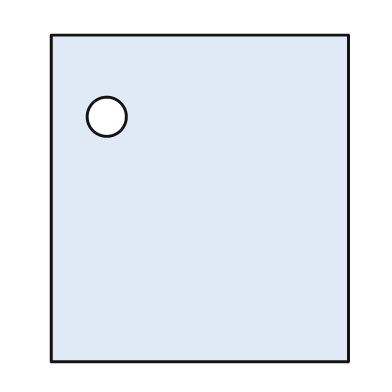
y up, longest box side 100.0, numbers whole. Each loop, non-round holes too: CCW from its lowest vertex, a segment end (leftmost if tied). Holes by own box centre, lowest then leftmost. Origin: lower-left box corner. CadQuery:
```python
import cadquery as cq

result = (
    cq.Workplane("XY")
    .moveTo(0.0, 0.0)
    .lineTo(91.0, 0.0)
    .lineTo(91.0, 100.0)
    .lineTo(0.0, 100.0)
    .close()
    .moveTo(17.0, 75.0)
    .circle(6.0)
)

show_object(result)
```